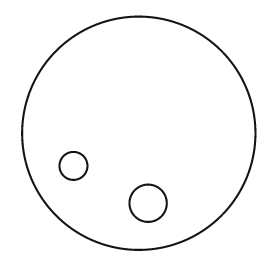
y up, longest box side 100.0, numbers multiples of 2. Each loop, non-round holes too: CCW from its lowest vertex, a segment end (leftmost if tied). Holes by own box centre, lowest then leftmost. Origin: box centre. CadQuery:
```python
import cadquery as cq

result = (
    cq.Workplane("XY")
    .moveTo(0.0, 0.0)
    .circle(50.0)
    .moveTo(4.0, -30.0)
    .circle(8.0)
    .moveTo(-28.0, -14.0)
    .circle(6.0)
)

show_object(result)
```